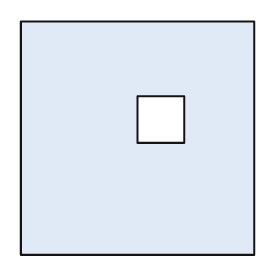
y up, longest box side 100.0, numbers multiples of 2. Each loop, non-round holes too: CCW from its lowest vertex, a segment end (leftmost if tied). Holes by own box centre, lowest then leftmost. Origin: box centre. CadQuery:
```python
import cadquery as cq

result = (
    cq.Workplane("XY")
    .moveTo(-50.0, -50.0)
    .lineTo(50.0, -50.0)
    .lineTo(50.0, 50.0)
    .lineTo(-50.0, 50.0)
    .close()
    .moveTo(0.0, -2.0)
    .lineTo(20.0, -2.0)
    .lineTo(20.0, 18.0)
    .lineTo(0.0, 18.0)
    .close()
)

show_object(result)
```